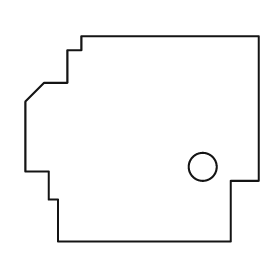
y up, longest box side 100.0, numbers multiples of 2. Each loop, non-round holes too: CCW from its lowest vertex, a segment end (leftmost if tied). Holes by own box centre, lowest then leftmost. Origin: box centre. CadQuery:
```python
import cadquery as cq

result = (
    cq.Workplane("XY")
    .moveTo(-36.0, -44.0)
    .lineTo(38.0, -44.0)
    .lineTo(38.0, -18.0)
    .lineTo(50.0, -18.0)
    .lineTo(50.0, 44.0)
    .lineTo(-26.0, 44.0)
    .lineTo(-26.0, 38.0)
    .lineTo(-32.0, 38.0)
    .lineTo(-32.0, 24.0)
    .lineTo(-42.0, 24.0)
    .lineTo(-50.0, 16.0)
    .lineTo(-50.0, -14.0)
    .lineTo(-40.0, -14.0)
    .lineTo(-40.0, -26.0)
    .lineTo(-36.0, -26.0)
    .close()
    .moveTo(26.0, -12.0)
    .circle(6.0)
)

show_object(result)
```